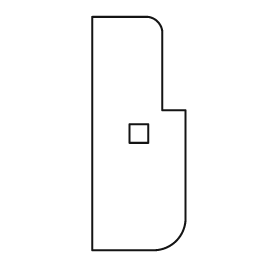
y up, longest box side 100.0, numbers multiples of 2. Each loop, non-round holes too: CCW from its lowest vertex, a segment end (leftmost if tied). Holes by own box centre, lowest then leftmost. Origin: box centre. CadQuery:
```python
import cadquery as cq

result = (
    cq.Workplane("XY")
    .moveTo(-20.0, -50.0)
    .lineTo(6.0, -50.0)
    .threePointArc((16.0, -46.0), (20.0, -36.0))
    .lineTo(20.0, 10.0)
    .lineTo(10.0, 10.0)
    .lineTo(10.0, 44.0)
    .threePointArc((8.0, 48.0), (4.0, 50.0))
    .lineTo(-20.0, 50.0)
    .close()
    .moveTo(-4.0, -4.0)
    .lineTo(4.0, -4.0)
    .lineTo(4.0, 4.0)
    .lineTo(-4.0, 4.0)
    .close()
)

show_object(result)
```